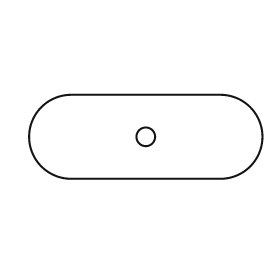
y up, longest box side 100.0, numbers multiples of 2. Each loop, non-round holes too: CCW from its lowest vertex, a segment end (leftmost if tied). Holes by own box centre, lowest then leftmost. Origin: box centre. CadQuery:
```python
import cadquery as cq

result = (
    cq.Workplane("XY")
    .moveTo(-32.0, -18.0)
    .lineTo(32.0, -18.0)
    .threePointArc((50.0, 0.0), (32.0, 18.0))
    .lineTo(-32.0, 18.0)
    .threePointArc((-50.0, 0.0), (-32.0, -18.0))
    .close()
    .moveTo(0.0, 0.0)
    .circle(4.0)
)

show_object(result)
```